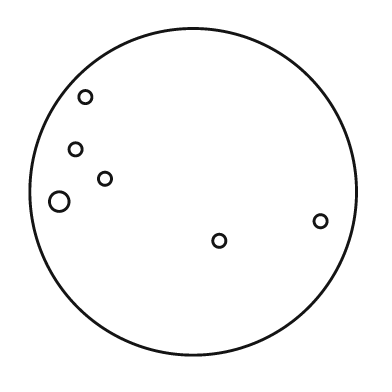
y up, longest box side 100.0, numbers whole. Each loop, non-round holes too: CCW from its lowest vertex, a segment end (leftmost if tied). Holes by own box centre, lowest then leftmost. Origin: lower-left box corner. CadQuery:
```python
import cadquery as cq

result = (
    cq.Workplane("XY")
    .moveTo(50.0, 50.0)
    .circle(50.0)
    .moveTo(58.0, 35.0)
    .circle(2.0)
    .moveTo(89.0, 41.0)
    .circle(2.0)
    .moveTo(9.0, 47.0)
    .circle(3.0)
    .moveTo(23.0, 54.0)
    .circle(2.0)
    .moveTo(14.0, 63.0)
    .circle(2.0)
    .moveTo(17.0, 79.0)
    .circle(2.0)
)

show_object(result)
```